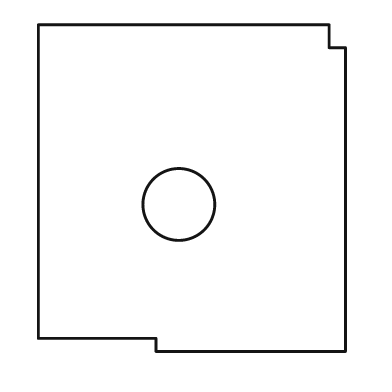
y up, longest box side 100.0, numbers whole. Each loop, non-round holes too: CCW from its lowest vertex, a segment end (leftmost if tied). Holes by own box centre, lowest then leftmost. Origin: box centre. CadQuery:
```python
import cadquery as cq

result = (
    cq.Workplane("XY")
    .moveTo(-11.0, -50.0)
    .lineTo(47.0, -50.0)
    .lineTo(47.0, 43.0)
    .lineTo(42.0, 43.0)
    .lineTo(42.0, 50.0)
    .lineTo(-47.0, 50.0)
    .lineTo(-47.0, -46.0)
    .lineTo(-11.0, -46.0)
    .close()
    .moveTo(-4.0, -5.0)
    .circle(11.0)
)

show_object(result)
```